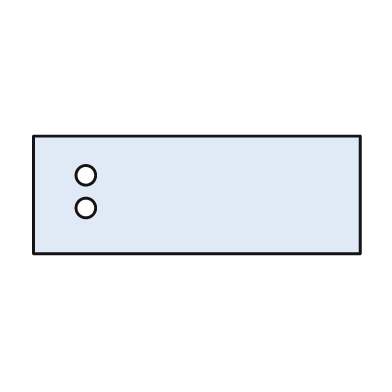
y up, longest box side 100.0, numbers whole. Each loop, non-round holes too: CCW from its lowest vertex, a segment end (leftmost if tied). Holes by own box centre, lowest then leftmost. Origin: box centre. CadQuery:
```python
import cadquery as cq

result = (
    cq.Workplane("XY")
    .moveTo(-50.0, -18.0)
    .lineTo(50.0, -18.0)
    .lineTo(50.0, 18.0)
    .lineTo(-50.0, 18.0)
    .close()
    .moveTo(-34.0, -4.0)
    .circle(3.0)
    .moveTo(-34.0, 6.0)
    .circle(3.0)
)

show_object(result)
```